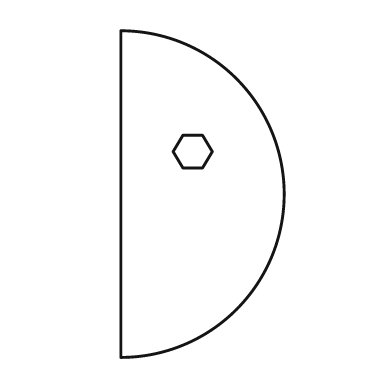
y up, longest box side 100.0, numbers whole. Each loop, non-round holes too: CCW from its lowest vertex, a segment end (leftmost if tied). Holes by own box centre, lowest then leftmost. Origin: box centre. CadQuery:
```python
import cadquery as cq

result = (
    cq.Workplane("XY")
    .moveTo(-25.0, -50.0)
    .threePointArc((25.0, 0.0), (-25.0, 50.0))
    .close()
    .moveTo(-6.0, 8.0)
    .lineTo(0.0, 8.0)
    .lineTo(3.0, 13.0)
    .lineTo(0.0, 18.0)
    .lineTo(-6.0, 18.0)
    .lineTo(-9.0, 13.0)
    .close()
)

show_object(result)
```